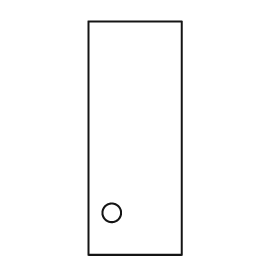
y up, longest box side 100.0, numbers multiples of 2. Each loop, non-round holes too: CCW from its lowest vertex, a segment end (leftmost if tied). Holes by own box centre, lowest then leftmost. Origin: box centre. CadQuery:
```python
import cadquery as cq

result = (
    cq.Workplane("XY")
    .moveTo(-20.0, -50.0)
    .lineTo(20.0, -50.0)
    .lineTo(20.0, 50.0)
    .lineTo(-20.0, 50.0)
    .close()
    .moveTo(-10.0, -32.0)
    .circle(4.0)
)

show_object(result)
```